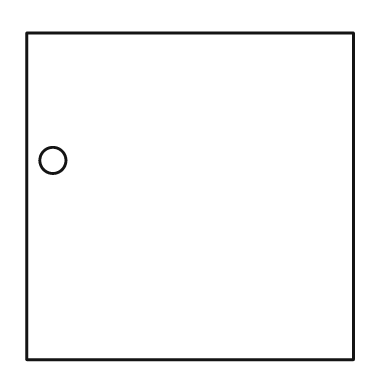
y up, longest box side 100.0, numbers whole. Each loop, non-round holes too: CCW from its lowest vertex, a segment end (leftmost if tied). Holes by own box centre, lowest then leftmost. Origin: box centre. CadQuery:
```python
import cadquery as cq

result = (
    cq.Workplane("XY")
    .moveTo(-50.0, -50.0)
    .lineTo(50.0, -50.0)
    .lineTo(50.0, 50.0)
    .lineTo(-50.0, 50.0)
    .close()
    .moveTo(-42.0, 11.0)
    .circle(4.0)
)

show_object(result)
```